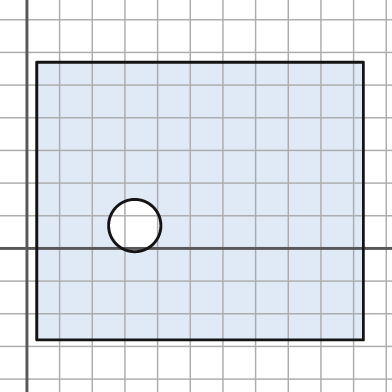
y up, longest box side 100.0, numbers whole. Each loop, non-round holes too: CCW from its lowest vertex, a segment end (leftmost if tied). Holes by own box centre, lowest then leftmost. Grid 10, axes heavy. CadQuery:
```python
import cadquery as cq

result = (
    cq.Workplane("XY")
    .moveTo(3.0, -28.0)
    .lineTo(103.0, -28.0)
    .lineTo(103.0, 57.0)
    .lineTo(3.0, 57.0)
    .close()
    .moveTo(33.0, 7.0)
    .circle(8.0)
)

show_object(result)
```